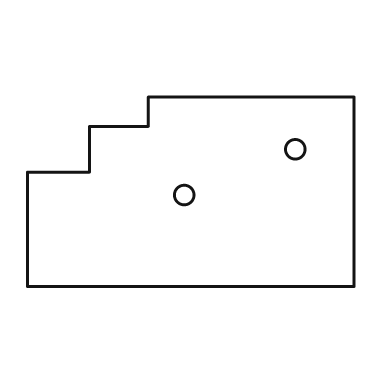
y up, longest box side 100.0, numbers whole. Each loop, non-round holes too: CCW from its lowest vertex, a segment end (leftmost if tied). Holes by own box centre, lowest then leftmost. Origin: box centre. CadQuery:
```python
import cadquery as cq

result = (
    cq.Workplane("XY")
    .moveTo(-50.0, -29.0)
    .lineTo(50.0, -29.0)
    .lineTo(50.0, 29.0)
    .lineTo(-13.0, 29.0)
    .lineTo(-13.0, 20.0)
    .lineTo(-31.0, 20.0)
    .lineTo(-31.0, 6.0)
    .lineTo(-50.0, 6.0)
    .close()
    .moveTo(-2.0, -1.0)
    .circle(3.0)
    .moveTo(32.0, 13.0)
    .circle(3.0)
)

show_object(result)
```